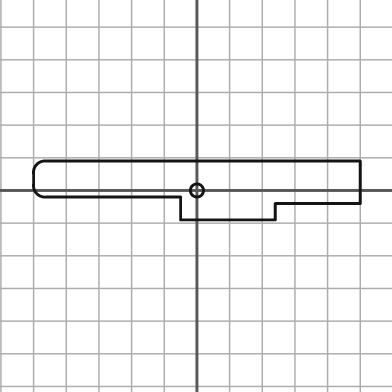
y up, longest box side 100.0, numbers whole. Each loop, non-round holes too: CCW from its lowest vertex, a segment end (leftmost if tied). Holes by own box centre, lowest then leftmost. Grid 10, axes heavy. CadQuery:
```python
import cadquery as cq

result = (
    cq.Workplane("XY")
    .moveTo(-5.0, -9.0)
    .lineTo(24.0, -9.0)
    .lineTo(24.0, -4.0)
    .lineTo(50.0, -4.0)
    .lineTo(50.0, 9.0)
    .lineTo(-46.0, 9.0)
    .threePointArc((-49.0, 8.0), (-50.0, 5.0))
    .lineTo(-50.0, 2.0)
    .threePointArc((-49.0, -1.0), (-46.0, -2.0))
    .lineTo(-5.0, -2.0)
    .close()
    .moveTo(0.0, 0.0)
    .circle(2.0)
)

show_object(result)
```